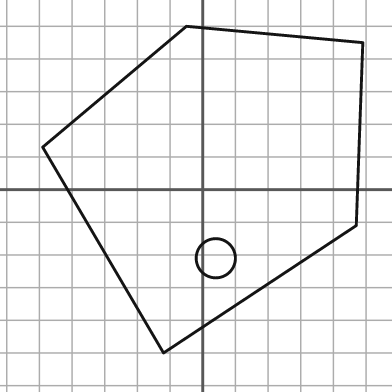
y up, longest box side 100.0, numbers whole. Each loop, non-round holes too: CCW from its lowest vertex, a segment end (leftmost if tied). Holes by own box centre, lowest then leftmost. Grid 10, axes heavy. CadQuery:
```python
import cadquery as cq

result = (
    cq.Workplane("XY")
    .moveTo(-12.0, -50.0)
    .lineTo(47.0, -11.0)
    .lineTo(49.0, 45.0)
    .lineTo(-5.0, 50.0)
    .lineTo(-49.0, 13.0)
    .close()
    .moveTo(4.0, -21.0)
    .circle(6.0)
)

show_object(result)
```